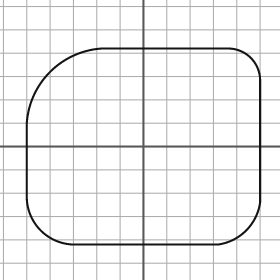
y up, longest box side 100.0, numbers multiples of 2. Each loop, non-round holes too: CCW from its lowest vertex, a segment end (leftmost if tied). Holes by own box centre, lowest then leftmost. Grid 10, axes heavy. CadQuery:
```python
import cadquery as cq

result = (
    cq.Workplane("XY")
    .moveTo(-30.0, -42.0)
    .lineTo(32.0, -42.0)
    .threePointArc((44.0, -36.0), (50.0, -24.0))
    .lineTo(50.0, 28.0)
    .threePointArc((46.0, 38.0), (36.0, 42.0))
    .lineTo(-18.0, 42.0)
    .threePointArc((-40.0, 32.0), (-50.0, 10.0))
    .lineTo(-50.0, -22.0)
    .threePointArc((-44.0, -36.0), (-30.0, -42.0))
    .close()
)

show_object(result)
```